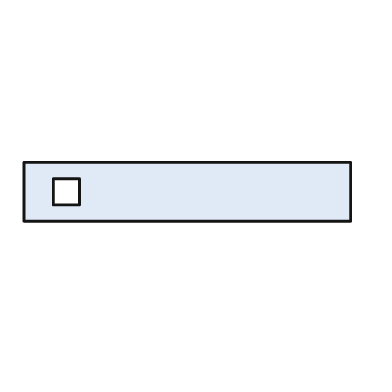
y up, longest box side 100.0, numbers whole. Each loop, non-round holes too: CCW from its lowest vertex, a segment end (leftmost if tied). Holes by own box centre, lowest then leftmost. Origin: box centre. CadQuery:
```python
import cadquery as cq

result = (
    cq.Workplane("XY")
    .moveTo(-50.0, -9.0)
    .lineTo(50.0, -9.0)
    .lineTo(50.0, 9.0)
    .lineTo(-50.0, 9.0)
    .close()
    .moveTo(-41.0, -4.0)
    .lineTo(-33.0, -4.0)
    .lineTo(-33.0, 4.0)
    .lineTo(-41.0, 4.0)
    .close()
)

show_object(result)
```